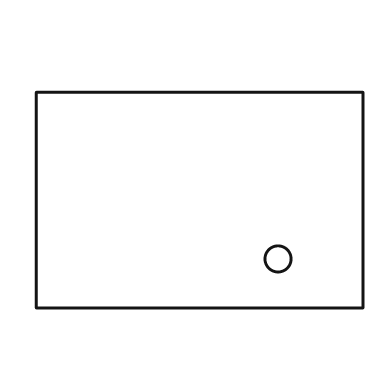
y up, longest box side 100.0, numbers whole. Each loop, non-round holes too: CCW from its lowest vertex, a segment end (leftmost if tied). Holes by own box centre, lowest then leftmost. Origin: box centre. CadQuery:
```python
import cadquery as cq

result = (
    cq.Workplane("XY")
    .moveTo(-50.0, -33.0)
    .lineTo(50.0, -33.0)
    .lineTo(50.0, 33.0)
    .lineTo(-50.0, 33.0)
    .close()
    .moveTo(24.0, -18.0)
    .circle(4.0)
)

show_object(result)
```